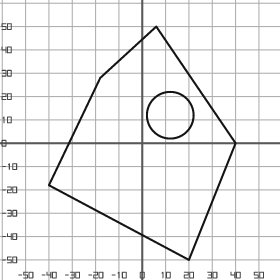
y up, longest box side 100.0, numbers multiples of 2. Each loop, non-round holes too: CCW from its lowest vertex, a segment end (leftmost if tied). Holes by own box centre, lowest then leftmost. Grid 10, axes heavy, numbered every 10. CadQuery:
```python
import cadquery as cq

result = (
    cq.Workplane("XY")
    .moveTo(20.0, -50.0)
    .lineTo(40.0, 0.0)
    .lineTo(6.0, 50.0)
    .lineTo(-18.0, 28.0)
    .lineTo(-40.0, -18.0)
    .close()
    .moveTo(12.0, 12.0)
    .circle(10.0)
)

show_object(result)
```